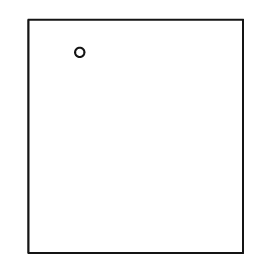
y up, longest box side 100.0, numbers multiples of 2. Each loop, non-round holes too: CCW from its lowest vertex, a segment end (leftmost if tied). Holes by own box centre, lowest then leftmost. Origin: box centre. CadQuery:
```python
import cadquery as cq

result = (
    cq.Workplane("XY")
    .moveTo(-46.0, -50.0)
    .lineTo(46.0, -50.0)
    .lineTo(46.0, 50.0)
    .lineTo(-46.0, 50.0)
    .close()
    .moveTo(-24.0, 36.0)
    .circle(2.0)
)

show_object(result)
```